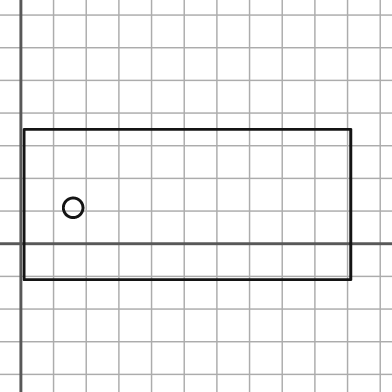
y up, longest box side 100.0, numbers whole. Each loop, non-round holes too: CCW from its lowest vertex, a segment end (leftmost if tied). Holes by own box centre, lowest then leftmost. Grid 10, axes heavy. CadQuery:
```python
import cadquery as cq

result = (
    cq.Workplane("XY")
    .moveTo(1.0, -11.0)
    .lineTo(101.0, -11.0)
    .lineTo(101.0, 35.0)
    .lineTo(1.0, 35.0)
    .close()
    .moveTo(16.0, 11.0)
    .circle(3.0)
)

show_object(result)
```